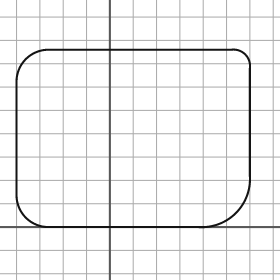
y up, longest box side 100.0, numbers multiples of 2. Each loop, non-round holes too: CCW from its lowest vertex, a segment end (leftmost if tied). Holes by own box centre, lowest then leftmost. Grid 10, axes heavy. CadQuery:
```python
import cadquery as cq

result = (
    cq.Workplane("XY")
    .moveTo(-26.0, 0.0)
    .lineTo(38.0, 0.0)
    .threePointArc((54.0, 6.0), (60.0, 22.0))
    .lineTo(60.0, 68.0)
    .threePointArc((58.0, 74.0), (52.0, 76.0))
    .lineTo(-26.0, 76.0)
    .threePointArc((-36.0, 72.0), (-40.0, 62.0))
    .lineTo(-40.0, 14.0)
    .threePointArc((-36.0, 4.0), (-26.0, 0.0))
    .close()
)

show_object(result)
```